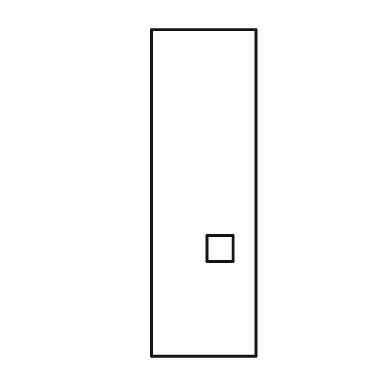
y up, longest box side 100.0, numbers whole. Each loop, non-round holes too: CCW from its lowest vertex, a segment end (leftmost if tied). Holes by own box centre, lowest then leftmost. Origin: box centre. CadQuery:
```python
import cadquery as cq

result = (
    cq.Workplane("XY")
    .moveTo(-16.0, -50.0)
    .lineTo(16.0, -50.0)
    .lineTo(16.0, 50.0)
    .lineTo(-16.0, 50.0)
    .close()
    .moveTo(1.0, -21.0)
    .lineTo(9.0, -21.0)
    .lineTo(9.0, -13.0)
    .lineTo(1.0, -13.0)
    .close()
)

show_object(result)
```